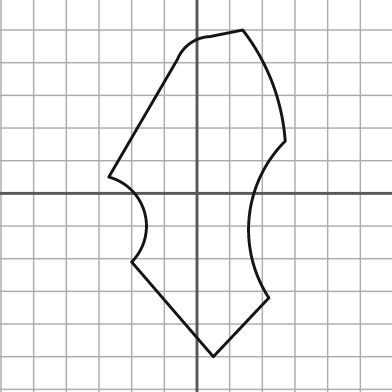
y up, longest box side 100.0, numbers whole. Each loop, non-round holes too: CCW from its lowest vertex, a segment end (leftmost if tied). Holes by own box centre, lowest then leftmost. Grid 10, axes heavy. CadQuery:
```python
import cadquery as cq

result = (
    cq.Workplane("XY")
    .moveTo(5.0, -50.0)
    .lineTo(22.0, -32.0)
    .threePointArc((16.0, -7.0), (27.0, 16.0))
    .threePointArc((23.0, 34.0), (14.0, 50.0))
    .lineTo(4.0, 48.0)
    .threePointArc((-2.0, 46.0), (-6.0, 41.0))
    .lineTo(-27.0, 5.0)
    .threePointArc((-16.0, -6.0), (-20.0, -21.0))
    .close()
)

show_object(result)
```